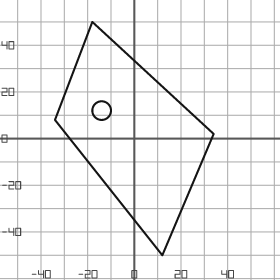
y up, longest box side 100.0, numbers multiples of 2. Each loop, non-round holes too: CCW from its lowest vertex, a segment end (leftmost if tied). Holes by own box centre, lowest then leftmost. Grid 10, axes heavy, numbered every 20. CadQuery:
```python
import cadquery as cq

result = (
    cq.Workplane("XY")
    .moveTo(12.0, -50.0)
    .lineTo(34.0, 2.0)
    .lineTo(-18.0, 50.0)
    .lineTo(-34.0, 8.0)
    .close()
    .moveTo(-14.0, 12.0)
    .circle(4.0)
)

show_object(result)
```